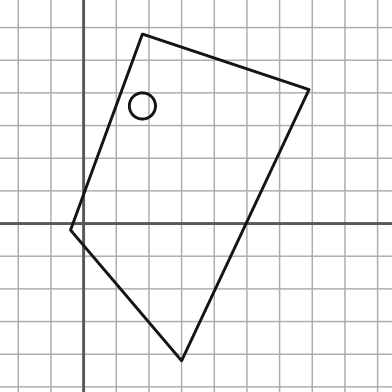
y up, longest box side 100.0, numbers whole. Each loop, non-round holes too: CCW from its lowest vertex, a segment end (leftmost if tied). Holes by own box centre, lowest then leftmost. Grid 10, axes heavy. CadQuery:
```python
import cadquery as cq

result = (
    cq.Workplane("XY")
    .moveTo(30.0, -42.0)
    .lineTo(69.0, 41.0)
    .lineTo(18.0, 58.0)
    .lineTo(-4.0, -2.0)
    .close()
    .moveTo(18.0, 36.0)
    .circle(4.0)
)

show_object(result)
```